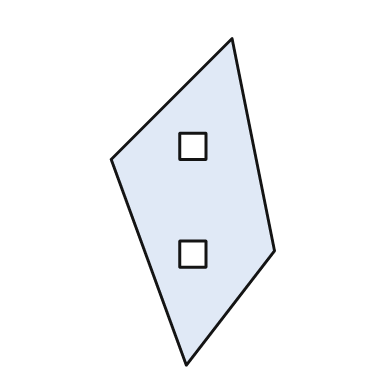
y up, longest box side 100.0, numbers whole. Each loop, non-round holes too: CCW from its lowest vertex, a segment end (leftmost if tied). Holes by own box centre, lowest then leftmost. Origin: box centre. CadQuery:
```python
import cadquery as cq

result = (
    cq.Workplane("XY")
    .moveTo(-2.0, -50.0)
    .lineTo(25.0, -15.0)
    .lineTo(12.0, 50.0)
    .lineTo(-25.0, 13.0)
    .close()
    .moveTo(-4.0, -20.0)
    .lineTo(4.0, -20.0)
    .lineTo(4.0, -12.0)
    .lineTo(-4.0, -12.0)
    .close()
    .moveTo(-4.0, 13.0)
    .lineTo(4.0, 13.0)
    .lineTo(4.0, 21.0)
    .lineTo(-4.0, 21.0)
    .close()
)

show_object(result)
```